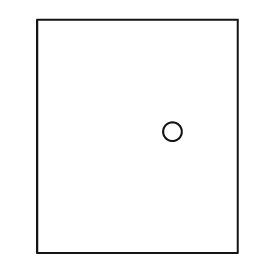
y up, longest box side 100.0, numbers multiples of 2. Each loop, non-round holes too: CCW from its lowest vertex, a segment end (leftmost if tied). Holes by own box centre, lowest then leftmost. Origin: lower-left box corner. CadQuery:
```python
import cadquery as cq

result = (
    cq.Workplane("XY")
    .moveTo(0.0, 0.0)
    .lineTo(86.0, 0.0)
    .lineTo(86.0, 100.0)
    .lineTo(0.0, 100.0)
    .close()
    .moveTo(58.0, 52.0)
    .circle(4.0)
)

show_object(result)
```